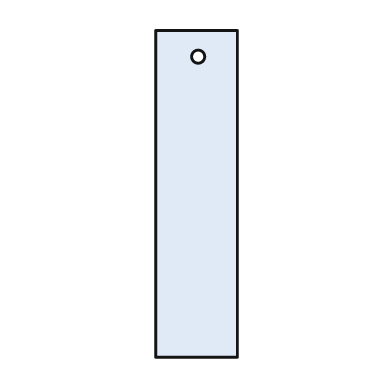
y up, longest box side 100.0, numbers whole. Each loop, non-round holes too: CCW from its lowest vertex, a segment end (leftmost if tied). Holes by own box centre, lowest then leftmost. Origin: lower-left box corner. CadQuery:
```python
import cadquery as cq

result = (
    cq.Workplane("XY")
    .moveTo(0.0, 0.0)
    .lineTo(25.0, 0.0)
    .lineTo(25.0, 100.0)
    .lineTo(0.0, 100.0)
    .close()
    .moveTo(13.0, 92.0)
    .circle(2.0)
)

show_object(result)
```